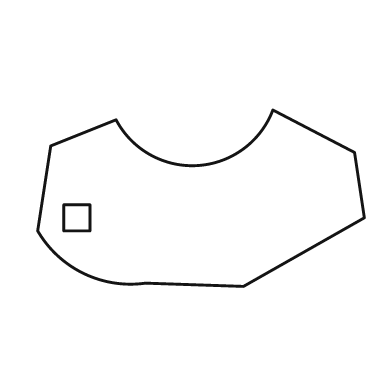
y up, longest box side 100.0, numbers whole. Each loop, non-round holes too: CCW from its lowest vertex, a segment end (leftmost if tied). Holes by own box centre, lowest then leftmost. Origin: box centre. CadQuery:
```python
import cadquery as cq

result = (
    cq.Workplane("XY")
    .moveTo(13.0, -27.0)
    .lineTo(50.0, -6.0)
    .lineTo(47.0, 14.0)
    .lineTo(22.0, 27.0)
    .threePointArc((-1.0, 10.0), (-26.0, 24.0))
    .lineTo(-46.0, 16.0)
    .lineTo(-50.0, -10.0)
    .threePointArc((-36.0, -23.0), (-17.0, -26.0))
    .close()
    .moveTo(-42.0, -10.0)
    .lineTo(-34.0, -10.0)
    .lineTo(-34.0, -2.0)
    .lineTo(-42.0, -2.0)
    .close()
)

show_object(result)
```